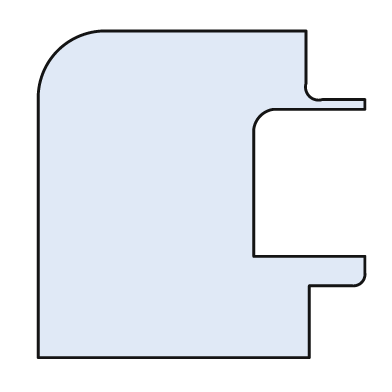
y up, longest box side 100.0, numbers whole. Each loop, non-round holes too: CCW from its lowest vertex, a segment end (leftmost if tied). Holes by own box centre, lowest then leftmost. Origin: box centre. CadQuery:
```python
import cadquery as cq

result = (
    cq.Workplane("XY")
    .moveTo(-50.0, -50.0)
    .lineTo(33.0, -50.0)
    .lineTo(33.0, -28.0)
    .lineTo(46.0, -28.0)
    .threePointArc((49.0, -27.0), (50.0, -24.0))
    .lineTo(50.0, -19.0)
    .lineTo(16.0, -19.0)
    .lineTo(16.0, 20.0)
    .threePointArc((18.0, 24.0), (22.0, 26.0))
    .lineTo(50.0, 26.0)
    .lineTo(50.0, 29.0)
    .lineTo(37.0, 29.0)
    .threePointArc((33.0, 30.0), (32.0, 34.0))
    .lineTo(32.0, 50.0)
    .lineTo(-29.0, 50.0)
    .threePointArc((-44.0, 44.0), (-50.0, 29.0))
    .close()
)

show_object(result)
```